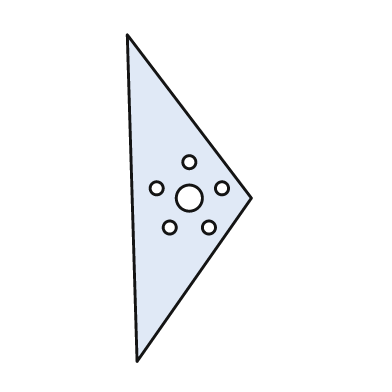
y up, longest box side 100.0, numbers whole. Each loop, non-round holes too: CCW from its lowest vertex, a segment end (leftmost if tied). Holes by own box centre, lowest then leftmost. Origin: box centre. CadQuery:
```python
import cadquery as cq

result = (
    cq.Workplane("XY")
    .moveTo(-16.0, -50.0)
    .lineTo(19.0, 0.0)
    .lineTo(-19.0, 50.0)
    .close()
    .moveTo(-6.0, -9.0)
    .circle(2.0)
    .moveTo(6.0, -9.0)
    .circle(2.0)
    .moveTo(0.0, 0.0)
    .circle(4.0)
    .moveTo(-10.0, 3.0)
    .circle(2.0)
    .moveTo(10.0, 3.0)
    .circle(2.0)
    .moveTo(0.0, 11.0)
    .circle(2.0)
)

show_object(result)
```